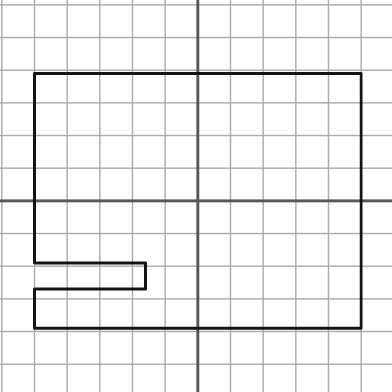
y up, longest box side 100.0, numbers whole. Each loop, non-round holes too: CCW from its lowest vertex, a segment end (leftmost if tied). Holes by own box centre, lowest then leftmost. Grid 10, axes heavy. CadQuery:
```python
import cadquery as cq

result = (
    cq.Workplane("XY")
    .moveTo(-50.0, -39.0)
    .lineTo(50.0, -39.0)
    .lineTo(50.0, 39.0)
    .lineTo(-50.0, 39.0)
    .lineTo(-50.0, -19.0)
    .lineTo(-16.0, -19.0)
    .lineTo(-16.0, -27.0)
    .lineTo(-50.0, -27.0)
    .close()
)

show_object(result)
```